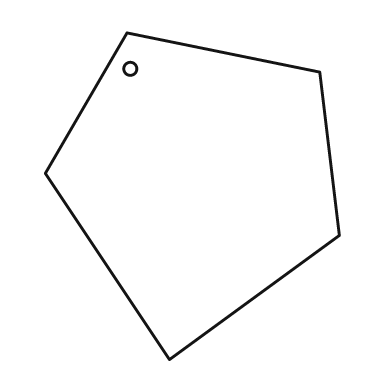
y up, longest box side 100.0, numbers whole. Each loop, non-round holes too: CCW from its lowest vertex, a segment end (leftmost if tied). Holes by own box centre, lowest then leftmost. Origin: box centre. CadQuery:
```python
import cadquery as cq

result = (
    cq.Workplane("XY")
    .moveTo(-7.0, -50.0)
    .lineTo(45.0, -12.0)
    .lineTo(39.0, 38.0)
    .lineTo(-20.0, 50.0)
    .lineTo(-45.0, 7.0)
    .close()
    .moveTo(-19.0, 39.0)
    .circle(2.0)
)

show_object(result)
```